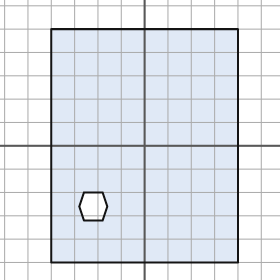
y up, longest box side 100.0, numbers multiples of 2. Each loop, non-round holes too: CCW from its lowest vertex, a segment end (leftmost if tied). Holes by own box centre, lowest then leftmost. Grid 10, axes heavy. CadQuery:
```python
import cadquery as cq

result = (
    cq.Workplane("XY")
    .moveTo(-40.0, -50.0)
    .lineTo(40.0, -50.0)
    .lineTo(40.0, 50.0)
    .lineTo(-40.0, 50.0)
    .close()
    .moveTo(-26.0, -32.0)
    .lineTo(-18.0, -32.0)
    .lineTo(-16.0, -26.0)
    .lineTo(-18.0, -20.0)
    .lineTo(-26.0, -20.0)
    .lineTo(-28.0, -26.0)
    .close()
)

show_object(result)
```